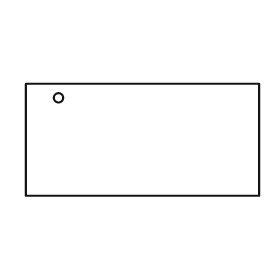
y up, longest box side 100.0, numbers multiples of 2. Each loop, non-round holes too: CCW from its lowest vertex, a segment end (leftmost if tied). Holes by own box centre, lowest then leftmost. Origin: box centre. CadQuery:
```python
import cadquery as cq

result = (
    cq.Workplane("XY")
    .moveTo(-50.0, -24.0)
    .lineTo(50.0, -24.0)
    .lineTo(50.0, 24.0)
    .lineTo(-50.0, 24.0)
    .close()
    .moveTo(-36.0, 18.0)
    .circle(2.0)
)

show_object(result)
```